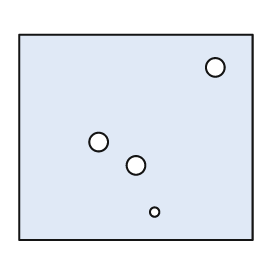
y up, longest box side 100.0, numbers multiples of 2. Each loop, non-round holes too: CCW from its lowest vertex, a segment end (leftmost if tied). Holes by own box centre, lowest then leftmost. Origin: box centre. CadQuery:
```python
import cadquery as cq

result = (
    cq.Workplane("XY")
    .moveTo(-50.0, -44.0)
    .lineTo(50.0, -44.0)
    .lineTo(50.0, 44.0)
    .lineTo(-50.0, 44.0)
    .close()
    .moveTo(8.0, -32.0)
    .circle(2.0)
    .moveTo(0.0, -12.0)
    .circle(4.0)
    .moveTo(-16.0, -2.0)
    .circle(4.0)
    .moveTo(34.0, 30.0)
    .circle(4.0)
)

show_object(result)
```